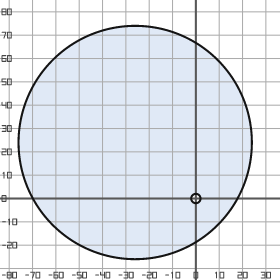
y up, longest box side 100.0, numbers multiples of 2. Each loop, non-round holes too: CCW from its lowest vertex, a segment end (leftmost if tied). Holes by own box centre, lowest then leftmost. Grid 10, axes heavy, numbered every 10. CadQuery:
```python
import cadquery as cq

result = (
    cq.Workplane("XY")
    .moveTo(-26.0, 24.0)
    .circle(50.0)
    .moveTo(0.0, 0.0)
    .circle(2.0)
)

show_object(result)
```